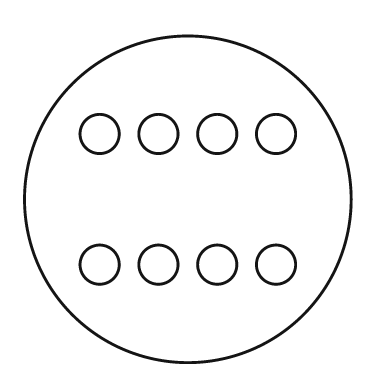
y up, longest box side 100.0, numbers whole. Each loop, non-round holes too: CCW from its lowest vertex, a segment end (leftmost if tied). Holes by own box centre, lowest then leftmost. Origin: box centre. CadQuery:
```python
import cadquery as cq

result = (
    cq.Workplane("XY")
    .moveTo(0.0, 0.0)
    .circle(50.0)
    .moveTo(-27.0, -20.0)
    .circle(6.0)
    .moveTo(-9.0, -20.0)
    .circle(6.0)
    .moveTo(9.0, -20.0)
    .circle(6.0)
    .moveTo(27.0, -20.0)
    .circle(6.0)
    .moveTo(-27.0, 20.0)
    .circle(6.0)
    .moveTo(-9.0, 20.0)
    .circle(6.0)
    .moveTo(9.0, 20.0)
    .circle(6.0)
    .moveTo(27.0, 20.0)
    .circle(6.0)
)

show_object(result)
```